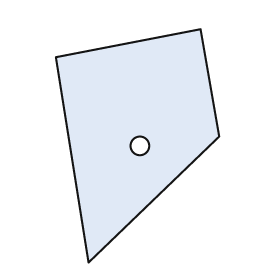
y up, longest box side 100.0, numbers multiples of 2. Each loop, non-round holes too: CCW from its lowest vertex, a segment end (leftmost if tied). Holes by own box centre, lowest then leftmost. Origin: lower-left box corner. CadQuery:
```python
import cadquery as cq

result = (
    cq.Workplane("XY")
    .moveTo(14.0, 0.0)
    .lineTo(70.0, 54.0)
    .lineTo(62.0, 100.0)
    .lineTo(0.0, 88.0)
    .close()
    .moveTo(36.0, 50.0)
    .circle(4.0)
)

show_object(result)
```